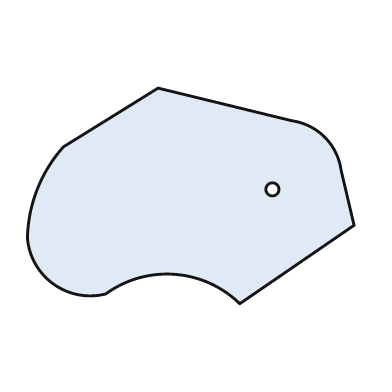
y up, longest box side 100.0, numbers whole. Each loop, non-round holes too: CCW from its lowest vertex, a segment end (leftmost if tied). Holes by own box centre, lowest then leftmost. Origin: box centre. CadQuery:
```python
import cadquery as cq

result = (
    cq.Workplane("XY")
    .moveTo(15.0, -33.0)
    .lineTo(50.0, -9.0)
    .lineTo(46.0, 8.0)
    .threePointArc((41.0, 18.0), (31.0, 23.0))
    .lineTo(-10.0, 33.0)
    .lineTo(-39.0, 15.0)
    .threePointArc((-47.0, 2.0), (-50.0, -13.0))
    .threePointArc((-42.0, -27.0), (-26.0, -30.0))
    .threePointArc((-5.0, -24.0), (15.0, -33.0))
    .close()
    .moveTo(25.0, 2.0)
    .circle(2.0)
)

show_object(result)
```